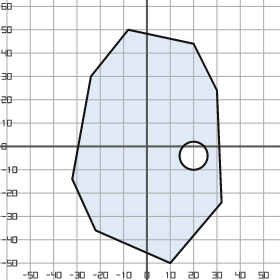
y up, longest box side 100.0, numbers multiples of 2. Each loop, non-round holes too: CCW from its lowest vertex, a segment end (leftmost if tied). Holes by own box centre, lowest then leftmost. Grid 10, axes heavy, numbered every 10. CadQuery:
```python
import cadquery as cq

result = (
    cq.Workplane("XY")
    .moveTo(10.0, -50.0)
    .lineTo(32.0, -24.0)
    .lineTo(30.0, 24.0)
    .lineTo(20.0, 44.0)
    .lineTo(-8.0, 50.0)
    .lineTo(-24.0, 30.0)
    .lineTo(-32.0, -14.0)
    .lineTo(-22.0, -36.0)
    .close()
    .moveTo(20.0, -4.0)
    .circle(6.0)
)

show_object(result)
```